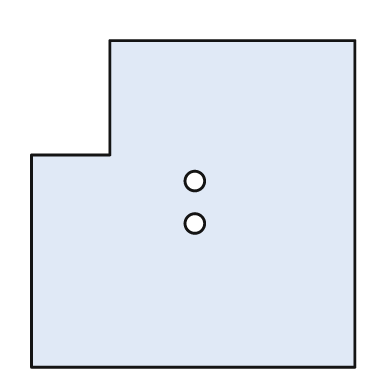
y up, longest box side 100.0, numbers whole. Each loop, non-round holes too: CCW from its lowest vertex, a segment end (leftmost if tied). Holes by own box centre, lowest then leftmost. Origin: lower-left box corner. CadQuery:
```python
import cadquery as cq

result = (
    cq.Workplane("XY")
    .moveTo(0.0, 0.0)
    .lineTo(99.0, 0.0)
    .lineTo(99.0, 100.0)
    .lineTo(24.0, 100.0)
    .lineTo(24.0, 65.0)
    .lineTo(0.0, 65.0)
    .close()
    .moveTo(50.0, 44.0)
    .circle(3.0)
    .moveTo(50.0, 57.0)
    .circle(3.0)
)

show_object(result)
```